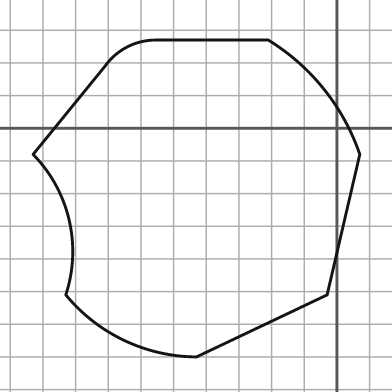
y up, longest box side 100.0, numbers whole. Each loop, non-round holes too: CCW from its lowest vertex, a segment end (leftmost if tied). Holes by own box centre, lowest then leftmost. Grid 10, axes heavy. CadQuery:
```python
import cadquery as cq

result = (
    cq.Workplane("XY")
    .moveTo(-43.0, -70.0)
    .lineTo(-3.0, -51.0)
    .lineTo(7.0, -8.0)
    .threePointArc((-4.0, 12.0), (-21.0, 27.0))
    .lineTo(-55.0, 27.0)
    .threePointArc((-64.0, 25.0), (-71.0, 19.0))
    .lineTo(-93.0, -8.0)
    .threePointArc((-82.0, -28.0), (-83.0, -51.0))
    .threePointArc((-65.0, -65.0), (-43.0, -70.0))
    .close()
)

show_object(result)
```